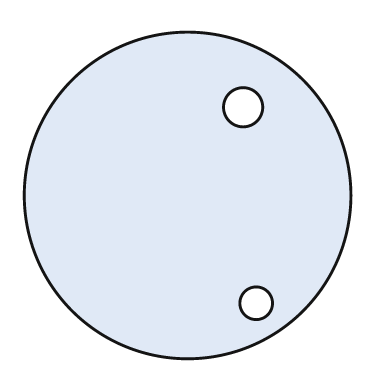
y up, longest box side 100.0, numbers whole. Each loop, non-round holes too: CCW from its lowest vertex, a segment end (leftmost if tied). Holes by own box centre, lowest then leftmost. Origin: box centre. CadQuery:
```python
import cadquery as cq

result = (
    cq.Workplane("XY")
    .moveTo(0.0, 0.0)
    .circle(50.0)
    .moveTo(21.0, -33.0)
    .circle(5.0)
    .moveTo(17.0, 27.0)
    .circle(6.0)
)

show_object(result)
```